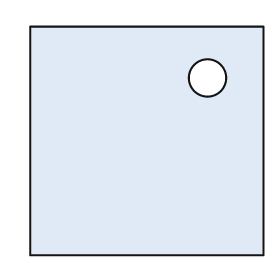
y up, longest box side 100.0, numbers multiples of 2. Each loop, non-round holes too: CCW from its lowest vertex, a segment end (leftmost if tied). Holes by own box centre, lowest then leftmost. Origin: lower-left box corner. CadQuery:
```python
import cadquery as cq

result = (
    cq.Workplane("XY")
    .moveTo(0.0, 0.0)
    .lineTo(100.0, 0.0)
    .lineTo(100.0, 98.0)
    .lineTo(0.0, 98.0)
    .close()
    .moveTo(76.0, 76.0)
    .circle(8.0)
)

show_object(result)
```